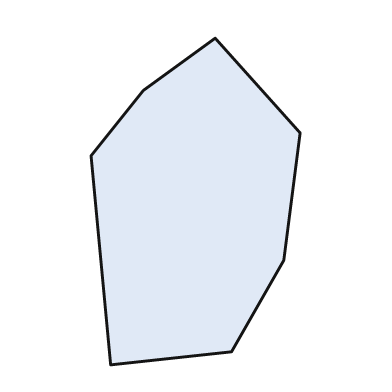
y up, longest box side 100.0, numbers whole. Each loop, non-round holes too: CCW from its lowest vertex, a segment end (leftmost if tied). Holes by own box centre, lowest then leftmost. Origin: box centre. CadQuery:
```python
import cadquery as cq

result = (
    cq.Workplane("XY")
    .moveTo(-26.0, -50.0)
    .lineTo(11.0, -46.0)
    .lineTo(27.0, -18.0)
    .lineTo(32.0, 21.0)
    .lineTo(6.0, 50.0)
    .lineTo(-16.0, 34.0)
    .lineTo(-32.0, 14.0)
    .close()
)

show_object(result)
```